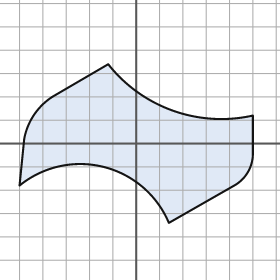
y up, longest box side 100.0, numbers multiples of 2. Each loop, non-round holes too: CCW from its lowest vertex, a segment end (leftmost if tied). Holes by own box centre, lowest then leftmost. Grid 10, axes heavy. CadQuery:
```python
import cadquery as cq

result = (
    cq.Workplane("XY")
    .moveTo(14.0, -34.0)
    .lineTo(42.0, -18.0)
    .threePointArc((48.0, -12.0), (50.0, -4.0))
    .lineTo(50.0, 12.0)
    .threePointArc((16.0, 14.0), (-12.0, 34.0))
    .lineTo(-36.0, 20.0)
    .threePointArc((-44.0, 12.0), (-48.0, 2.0))
    .lineTo(-50.0, -18.0)
    .threePointArc((-14.0, -10.0), (14.0, -34.0))
    .close()
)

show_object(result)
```